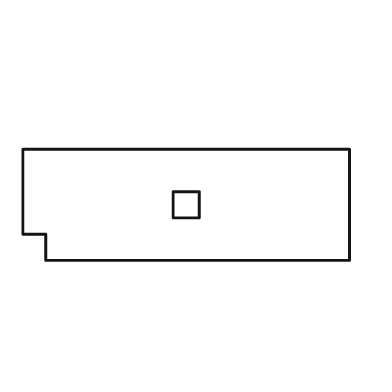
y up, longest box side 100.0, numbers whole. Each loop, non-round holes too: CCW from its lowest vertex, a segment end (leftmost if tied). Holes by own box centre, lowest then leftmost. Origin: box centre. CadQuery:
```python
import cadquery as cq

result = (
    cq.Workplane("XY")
    .moveTo(-43.0, -17.0)
    .lineTo(50.0, -17.0)
    .lineTo(50.0, 17.0)
    .lineTo(-50.0, 17.0)
    .lineTo(-50.0, -9.0)
    .lineTo(-43.0, -9.0)
    .close()
    .moveTo(-4.0, -4.0)
    .lineTo(4.0, -4.0)
    .lineTo(4.0, 4.0)
    .lineTo(-4.0, 4.0)
    .close()
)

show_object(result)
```